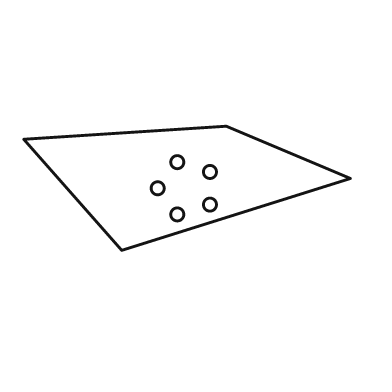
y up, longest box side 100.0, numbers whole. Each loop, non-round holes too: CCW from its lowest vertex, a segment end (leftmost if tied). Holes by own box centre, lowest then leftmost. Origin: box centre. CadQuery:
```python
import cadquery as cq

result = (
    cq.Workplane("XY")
    .moveTo(-20.0, -19.0)
    .lineTo(50.0, 3.0)
    .lineTo(12.0, 19.0)
    .lineTo(-50.0, 15.0)
    .close()
    .moveTo(-3.0, -8.0)
    .circle(2.0)
    .moveTo(7.0, -5.0)
    .circle(2.0)
    .moveTo(-9.0, 0.0)
    .circle(2.0)
    .moveTo(7.0, 5.0)
    .circle(2.0)
    .moveTo(-3.0, 8.0)
    .circle(2.0)
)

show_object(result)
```